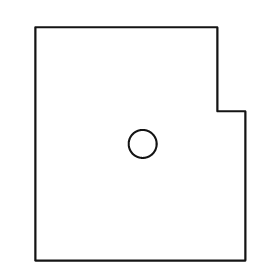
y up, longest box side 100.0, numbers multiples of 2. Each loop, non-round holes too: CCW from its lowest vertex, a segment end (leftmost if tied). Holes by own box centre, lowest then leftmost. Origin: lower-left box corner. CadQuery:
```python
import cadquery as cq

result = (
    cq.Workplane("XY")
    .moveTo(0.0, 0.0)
    .lineTo(90.0, 0.0)
    .lineTo(90.0, 64.0)
    .lineTo(78.0, 64.0)
    .lineTo(78.0, 100.0)
    .lineTo(0.0, 100.0)
    .close()
    .moveTo(46.0, 50.0)
    .circle(6.0)
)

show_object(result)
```